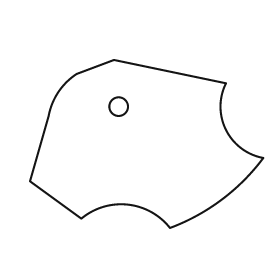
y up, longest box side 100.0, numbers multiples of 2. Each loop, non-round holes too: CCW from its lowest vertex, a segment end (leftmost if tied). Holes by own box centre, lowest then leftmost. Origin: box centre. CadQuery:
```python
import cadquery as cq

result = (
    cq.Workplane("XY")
    .moveTo(10.0, -36.0)
    .threePointArc((32.0, -24.0), (50.0, -6.0))
    .threePointArc((34.0, 6.0), (34.0, 26.0))
    .lineTo(-14.0, 36.0)
    .lineTo(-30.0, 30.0)
    .threePointArc((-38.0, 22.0), (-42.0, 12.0))
    .lineTo(-50.0, -16.0)
    .lineTo(-28.0, -32.0)
    .threePointArc((-8.0, -26.0), (10.0, -36.0))
    .close()
    .moveTo(-12.0, 16.0)
    .circle(4.0)
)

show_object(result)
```